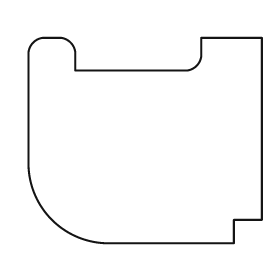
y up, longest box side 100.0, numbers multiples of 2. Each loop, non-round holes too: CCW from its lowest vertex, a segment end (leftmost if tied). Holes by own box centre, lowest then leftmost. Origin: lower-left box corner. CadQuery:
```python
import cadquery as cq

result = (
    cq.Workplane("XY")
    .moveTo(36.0, 0.0)
    .lineTo(88.0, 0.0)
    .lineTo(88.0, 10.0)
    .lineTo(100.0, 10.0)
    .lineTo(100.0, 88.0)
    .lineTo(74.0, 88.0)
    .lineTo(74.0, 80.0)
    .threePointArc((72.0, 76.0), (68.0, 74.0))
    .lineTo(20.0, 74.0)
    .lineTo(20.0, 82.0)
    .threePointArc((18.0, 86.0), (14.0, 88.0))
    .lineTo(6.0, 88.0)
    .threePointArc((2.0, 86.0), (0.0, 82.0))
    .lineTo(0.0, 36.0)
    .threePointArc((10.0, 10.0), (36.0, 0.0))
    .close()
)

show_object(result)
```